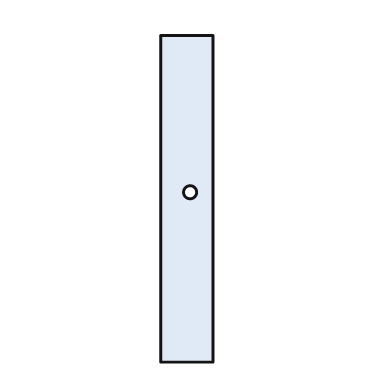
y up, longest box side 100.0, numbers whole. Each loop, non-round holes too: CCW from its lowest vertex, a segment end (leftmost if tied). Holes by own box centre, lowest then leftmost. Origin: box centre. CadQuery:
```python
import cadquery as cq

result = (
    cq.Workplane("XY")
    .moveTo(-8.0, -50.0)
    .lineTo(8.0, -50.0)
    .lineTo(8.0, 50.0)
    .lineTo(-8.0, 50.0)
    .close()
    .moveTo(1.0, 2.0)
    .circle(2.0)
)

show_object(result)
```